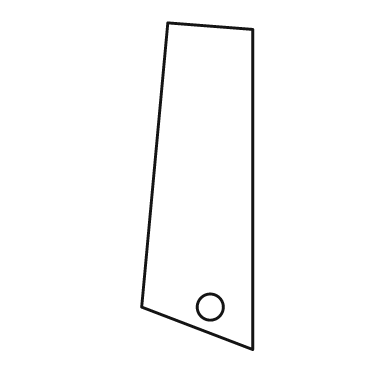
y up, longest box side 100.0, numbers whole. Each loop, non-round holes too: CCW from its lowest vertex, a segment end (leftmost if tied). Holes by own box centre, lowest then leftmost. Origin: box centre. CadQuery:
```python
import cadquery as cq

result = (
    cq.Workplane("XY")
    .moveTo(17.0, -50.0)
    .lineTo(17.0, 48.0)
    .lineTo(-9.0, 50.0)
    .lineTo(-17.0, -37.0)
    .close()
    .moveTo(4.0, -37.0)
    .circle(4.0)
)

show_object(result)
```